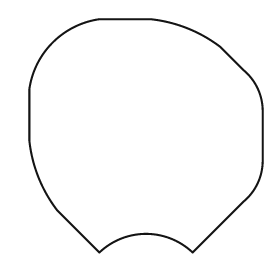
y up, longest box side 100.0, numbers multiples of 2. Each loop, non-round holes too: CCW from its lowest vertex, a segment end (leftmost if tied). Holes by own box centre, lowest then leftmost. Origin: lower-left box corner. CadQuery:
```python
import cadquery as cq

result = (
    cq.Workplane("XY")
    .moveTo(30.0, 0.0)
    .threePointArc((50.0, 8.0), (70.0, 0.0))
    .lineTo(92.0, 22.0)
    .threePointArc((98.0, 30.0), (100.0, 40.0))
    .lineTo(100.0, 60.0)
    .threePointArc((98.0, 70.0), (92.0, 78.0))
    .lineTo(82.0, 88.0)
    .threePointArc((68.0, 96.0), (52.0, 100.0))
    .lineTo(30.0, 100.0)
    .threePointArc((10.0, 90.0), (0.0, 70.0))
    .lineTo(0.0, 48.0)
    .threePointArc((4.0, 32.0), (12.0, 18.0))
    .close()
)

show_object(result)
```